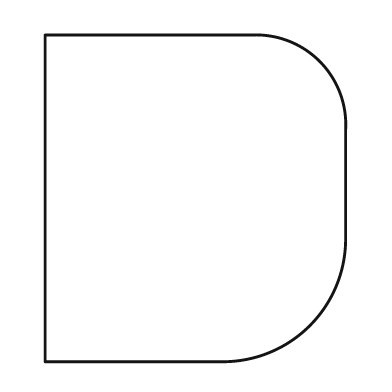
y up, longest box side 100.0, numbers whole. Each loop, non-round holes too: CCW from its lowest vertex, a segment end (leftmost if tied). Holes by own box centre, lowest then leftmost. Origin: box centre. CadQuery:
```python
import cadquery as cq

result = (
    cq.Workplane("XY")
    .moveTo(-46.0, -50.0)
    .lineTo(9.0, -50.0)
    .threePointArc((35.0, -39.0), (46.0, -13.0))
    .lineTo(46.0, 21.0)
    .threePointArc((38.0, 42.0), (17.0, 50.0))
    .lineTo(-46.0, 50.0)
    .close()
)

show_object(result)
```